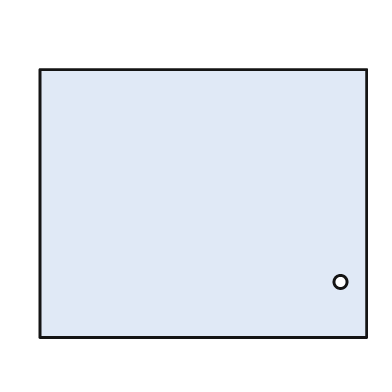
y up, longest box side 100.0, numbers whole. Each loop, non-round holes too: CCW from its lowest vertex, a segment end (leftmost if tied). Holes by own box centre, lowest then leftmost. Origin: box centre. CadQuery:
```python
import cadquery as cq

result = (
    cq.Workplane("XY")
    .moveTo(-50.0, -41.0)
    .lineTo(50.0, -41.0)
    .lineTo(50.0, 41.0)
    .lineTo(-50.0, 41.0)
    .close()
    .moveTo(42.0, -24.0)
    .circle(2.0)
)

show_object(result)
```